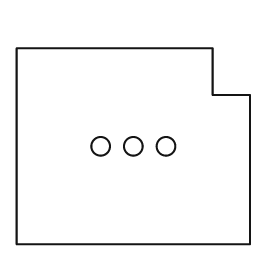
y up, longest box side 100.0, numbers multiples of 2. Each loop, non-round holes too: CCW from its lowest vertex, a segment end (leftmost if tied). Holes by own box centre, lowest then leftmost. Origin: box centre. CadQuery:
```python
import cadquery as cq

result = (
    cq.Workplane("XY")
    .moveTo(-50.0, -42.0)
    .lineTo(50.0, -42.0)
    .lineTo(50.0, 22.0)
    .lineTo(34.0, 22.0)
    .lineTo(34.0, 42.0)
    .lineTo(-50.0, 42.0)
    .close()
    .moveTo(-14.0, 0.0)
    .circle(4.0)
    .moveTo(0.0, 0.0)
    .circle(4.0)
    .moveTo(14.0, 0.0)
    .circle(4.0)
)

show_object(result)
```